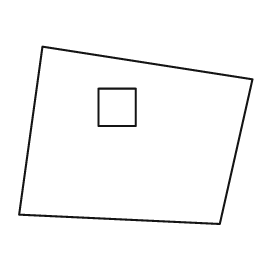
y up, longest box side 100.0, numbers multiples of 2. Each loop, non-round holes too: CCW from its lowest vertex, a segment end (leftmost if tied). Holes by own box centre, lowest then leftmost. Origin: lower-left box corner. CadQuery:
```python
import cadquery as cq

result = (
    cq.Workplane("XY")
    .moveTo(86.0, 0.0)
    .lineTo(100.0, 62.0)
    .lineTo(10.0, 76.0)
    .lineTo(0.0, 4.0)
    .close()
    .moveTo(34.0, 42.0)
    .lineTo(50.0, 42.0)
    .lineTo(50.0, 58.0)
    .lineTo(34.0, 58.0)
    .close()
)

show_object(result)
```